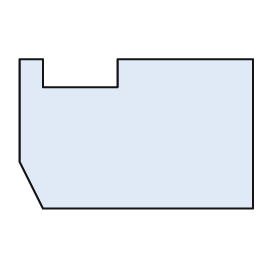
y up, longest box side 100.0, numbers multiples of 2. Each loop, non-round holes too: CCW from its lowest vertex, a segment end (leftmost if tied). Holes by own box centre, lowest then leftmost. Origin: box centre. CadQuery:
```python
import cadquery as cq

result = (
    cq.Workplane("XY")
    .moveTo(-40.0, -32.0)
    .lineTo(50.0, -32.0)
    .lineTo(50.0, 32.0)
    .lineTo(-8.0, 32.0)
    .lineTo(-8.0, 20.0)
    .lineTo(-40.0, 20.0)
    .lineTo(-40.0, 32.0)
    .lineTo(-50.0, 32.0)
    .lineTo(-50.0, -12.0)
    .close()
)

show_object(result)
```